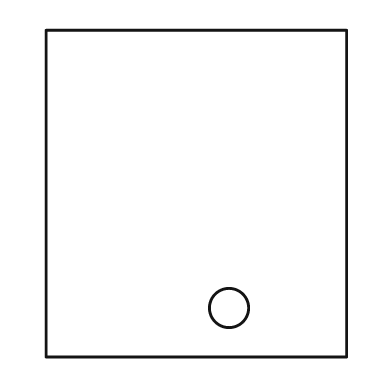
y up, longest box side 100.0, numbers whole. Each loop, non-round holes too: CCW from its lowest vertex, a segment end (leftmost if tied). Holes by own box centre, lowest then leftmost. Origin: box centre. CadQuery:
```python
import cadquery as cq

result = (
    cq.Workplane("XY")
    .moveTo(-46.0, -50.0)
    .lineTo(46.0, -50.0)
    .lineTo(46.0, 50.0)
    .lineTo(-46.0, 50.0)
    .close()
    .moveTo(10.0, -35.0)
    .circle(6.0)
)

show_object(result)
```